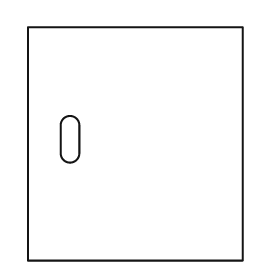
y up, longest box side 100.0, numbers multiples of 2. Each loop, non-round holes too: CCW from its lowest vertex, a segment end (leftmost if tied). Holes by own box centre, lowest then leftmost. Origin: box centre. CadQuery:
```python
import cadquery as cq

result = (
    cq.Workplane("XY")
    .moveTo(-46.0, -50.0)
    .lineTo(46.0, -50.0)
    .lineTo(46.0, 50.0)
    .lineTo(-46.0, 50.0)
    .close()
    .moveTo(-32.0, -4.0)
    .threePointArc((-28.0, -8.0), (-24.0, -4.0))
    .lineTo(-24.0, 8.0)
    .threePointArc((-28.0, 12.0), (-32.0, 8.0))
    .close()
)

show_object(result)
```